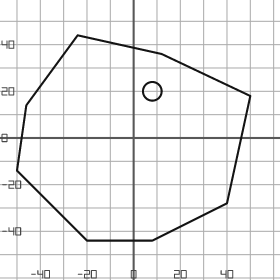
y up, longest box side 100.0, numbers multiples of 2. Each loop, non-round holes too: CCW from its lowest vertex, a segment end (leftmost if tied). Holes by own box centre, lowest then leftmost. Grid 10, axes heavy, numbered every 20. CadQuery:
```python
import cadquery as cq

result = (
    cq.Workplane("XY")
    .moveTo(-20.0, -44.0)
    .lineTo(8.0, -44.0)
    .lineTo(40.0, -28.0)
    .lineTo(50.0, 18.0)
    .lineTo(12.0, 36.0)
    .lineTo(-24.0, 44.0)
    .lineTo(-46.0, 14.0)
    .lineTo(-50.0, -14.0)
    .close()
    .moveTo(8.0, 20.0)
    .circle(4.0)
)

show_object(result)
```